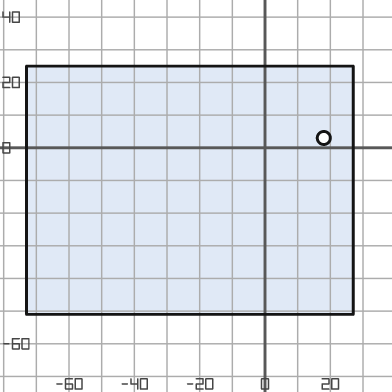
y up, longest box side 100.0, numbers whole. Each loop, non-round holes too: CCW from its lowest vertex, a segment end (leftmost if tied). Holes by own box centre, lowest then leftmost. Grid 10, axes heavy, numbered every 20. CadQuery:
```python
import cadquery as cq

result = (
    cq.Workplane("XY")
    .moveTo(-73.0, -51.0)
    .lineTo(27.0, -51.0)
    .lineTo(27.0, 25.0)
    .lineTo(-73.0, 25.0)
    .close()
    .moveTo(18.0, 3.0)
    .circle(2.0)
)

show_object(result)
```